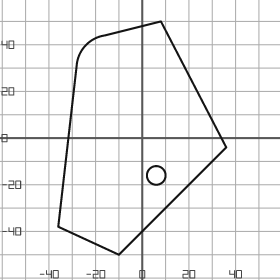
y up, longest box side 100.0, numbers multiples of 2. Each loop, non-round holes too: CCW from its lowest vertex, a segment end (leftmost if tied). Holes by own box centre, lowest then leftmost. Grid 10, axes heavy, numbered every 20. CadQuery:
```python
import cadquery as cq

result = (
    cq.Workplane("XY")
    .moveTo(-10.0, -50.0)
    .lineTo(36.0, -4.0)
    .lineTo(8.0, 50.0)
    .lineTo(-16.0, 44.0)
    .threePointArc((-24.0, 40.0), (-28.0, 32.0))
    .lineTo(-36.0, -38.0)
    .close()
    .moveTo(6.0, -16.0)
    .circle(4.0)
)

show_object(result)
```